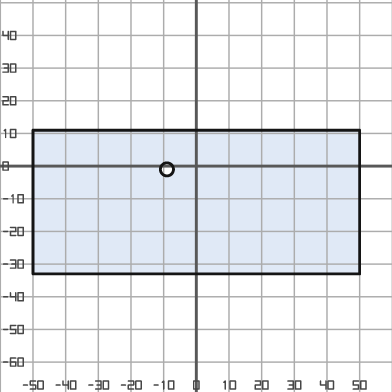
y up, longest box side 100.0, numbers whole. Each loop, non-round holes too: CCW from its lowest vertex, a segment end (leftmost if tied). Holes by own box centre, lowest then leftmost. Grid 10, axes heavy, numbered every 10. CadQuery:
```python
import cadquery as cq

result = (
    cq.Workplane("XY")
    .moveTo(-50.0, -33.0)
    .lineTo(50.0, -33.0)
    .lineTo(50.0, 11.0)
    .lineTo(-50.0, 11.0)
    .close()
    .moveTo(-9.0, -1.0)
    .circle(2.0)
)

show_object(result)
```